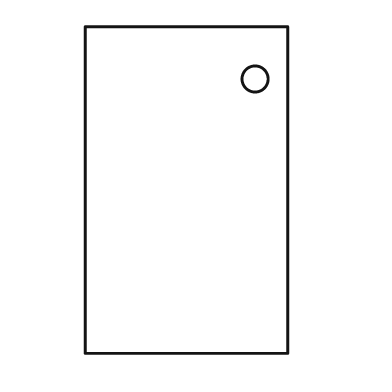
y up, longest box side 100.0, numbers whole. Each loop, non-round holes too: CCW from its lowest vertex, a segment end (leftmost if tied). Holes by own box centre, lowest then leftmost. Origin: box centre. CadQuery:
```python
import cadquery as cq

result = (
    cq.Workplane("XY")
    .moveTo(-31.0, -50.0)
    .lineTo(31.0, -50.0)
    .lineTo(31.0, 50.0)
    .lineTo(-31.0, 50.0)
    .close()
    .moveTo(21.0, 34.0)
    .circle(4.0)
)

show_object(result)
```